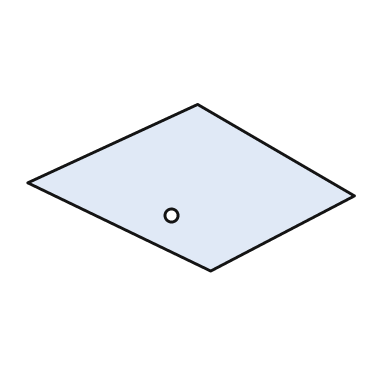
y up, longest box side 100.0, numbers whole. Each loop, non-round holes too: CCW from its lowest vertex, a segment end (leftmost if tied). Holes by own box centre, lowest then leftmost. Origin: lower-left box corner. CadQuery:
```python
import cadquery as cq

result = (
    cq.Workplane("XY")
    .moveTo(56.0, 0.0)
    .lineTo(100.0, 23.0)
    .lineTo(52.0, 51.0)
    .lineTo(0.0, 27.0)
    .close()
    .moveTo(44.0, 17.0)
    .circle(2.0)
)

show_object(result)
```